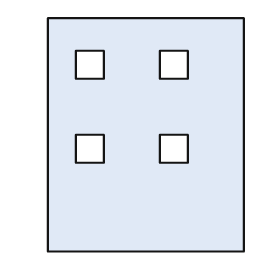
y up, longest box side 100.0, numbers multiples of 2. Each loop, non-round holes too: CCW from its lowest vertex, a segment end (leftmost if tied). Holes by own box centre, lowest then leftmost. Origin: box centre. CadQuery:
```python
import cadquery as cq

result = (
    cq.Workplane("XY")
    .moveTo(-42.0, -50.0)
    .lineTo(42.0, -50.0)
    .lineTo(42.0, 50.0)
    .lineTo(-42.0, 50.0)
    .close()
    .moveTo(-30.0, -12.0)
    .lineTo(-18.0, -12.0)
    .lineTo(-18.0, 0.0)
    .lineTo(-30.0, 0.0)
    .close()
    .moveTo(6.0, -12.0)
    .lineTo(18.0, -12.0)
    .lineTo(18.0, 0.0)
    .lineTo(6.0, 0.0)
    .close()
    .moveTo(-30.0, 24.0)
    .lineTo(-18.0, 24.0)
    .lineTo(-18.0, 36.0)
    .lineTo(-30.0, 36.0)
    .close()
    .moveTo(6.0, 24.0)
    .lineTo(18.0, 24.0)
    .lineTo(18.0, 36.0)
    .lineTo(6.0, 36.0)
    .close()
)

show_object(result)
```